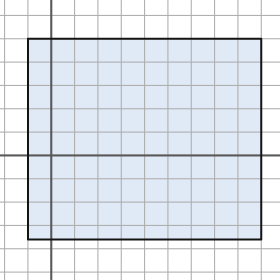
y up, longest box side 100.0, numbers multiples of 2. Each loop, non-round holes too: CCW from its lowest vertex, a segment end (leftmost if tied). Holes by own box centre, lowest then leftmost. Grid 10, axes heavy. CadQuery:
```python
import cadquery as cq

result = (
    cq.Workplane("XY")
    .moveTo(-10.0, -36.0)
    .lineTo(90.0, -36.0)
    .lineTo(90.0, 50.0)
    .lineTo(-10.0, 50.0)
    .close()
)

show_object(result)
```